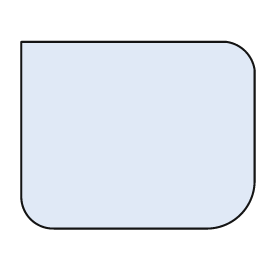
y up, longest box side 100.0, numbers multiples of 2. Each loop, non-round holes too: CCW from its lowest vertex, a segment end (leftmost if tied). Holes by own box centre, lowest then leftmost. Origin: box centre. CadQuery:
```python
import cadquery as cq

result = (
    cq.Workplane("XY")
    .moveTo(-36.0, -40.0)
    .lineTo(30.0, -40.0)
    .threePointArc((44.0, -34.0), (50.0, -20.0))
    .lineTo(50.0, 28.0)
    .threePointArc((46.0, 36.0), (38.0, 40.0))
    .lineTo(-50.0, 40.0)
    .lineTo(-50.0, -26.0)
    .threePointArc((-46.0, -36.0), (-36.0, -40.0))
    .close()
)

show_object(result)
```